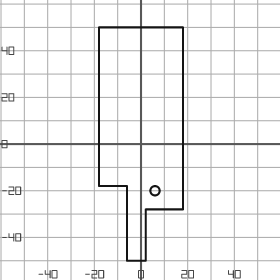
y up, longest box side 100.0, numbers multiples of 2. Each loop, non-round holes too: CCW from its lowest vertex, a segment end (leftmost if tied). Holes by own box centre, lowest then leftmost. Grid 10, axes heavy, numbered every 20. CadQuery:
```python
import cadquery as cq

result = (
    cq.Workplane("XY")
    .moveTo(-6.0, -50.0)
    .lineTo(2.0, -50.0)
    .lineTo(2.0, -28.0)
    .lineTo(18.0, -28.0)
    .lineTo(18.0, 50.0)
    .lineTo(-18.0, 50.0)
    .lineTo(-18.0, -18.0)
    .lineTo(-6.0, -18.0)
    .close()
    .moveTo(6.0, -20.0)
    .circle(2.0)
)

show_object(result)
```